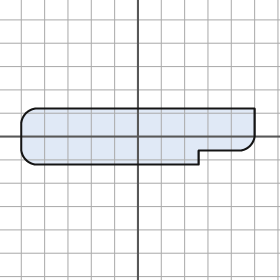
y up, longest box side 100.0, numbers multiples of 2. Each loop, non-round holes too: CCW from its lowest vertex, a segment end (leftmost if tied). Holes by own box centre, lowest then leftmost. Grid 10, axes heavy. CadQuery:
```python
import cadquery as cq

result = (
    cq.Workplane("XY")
    .moveTo(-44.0, -12.0)
    .lineTo(26.0, -12.0)
    .lineTo(26.0, -6.0)
    .lineTo(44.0, -6.0)
    .threePointArc((48.0, -4.0), (50.0, 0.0))
    .lineTo(50.0, 12.0)
    .lineTo(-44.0, 12.0)
    .threePointArc((-48.0, 10.0), (-50.0, 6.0))
    .lineTo(-50.0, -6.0)
    .threePointArc((-48.0, -10.0), (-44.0, -12.0))
    .close()
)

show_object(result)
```